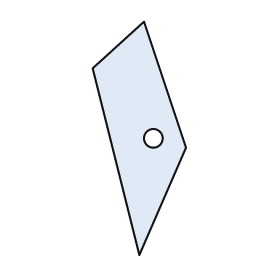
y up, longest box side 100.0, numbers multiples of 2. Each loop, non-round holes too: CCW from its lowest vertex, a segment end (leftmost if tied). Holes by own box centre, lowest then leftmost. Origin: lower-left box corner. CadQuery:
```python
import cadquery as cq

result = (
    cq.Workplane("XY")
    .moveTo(20.0, 0.0)
    .lineTo(40.0, 46.0)
    .lineTo(22.0, 100.0)
    .lineTo(0.0, 80.0)
    .close()
    .moveTo(26.0, 50.0)
    .circle(4.0)
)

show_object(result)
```